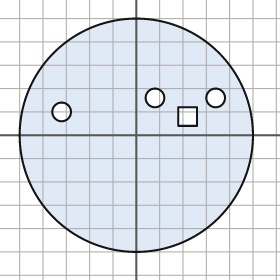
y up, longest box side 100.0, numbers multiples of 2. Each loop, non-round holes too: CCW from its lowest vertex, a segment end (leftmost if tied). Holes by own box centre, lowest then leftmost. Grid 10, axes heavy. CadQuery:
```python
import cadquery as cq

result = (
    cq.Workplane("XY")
    .moveTo(0.0, 0.0)
    .circle(50.0)
    .moveTo(18.0, 4.0)
    .lineTo(26.0, 4.0)
    .lineTo(26.0, 12.0)
    .lineTo(18.0, 12.0)
    .close()
    .moveTo(-32.0, 10.0)
    .circle(4.0)
    .moveTo(8.0, 16.0)
    .circle(4.0)
    .moveTo(34.0, 16.0)
    .circle(4.0)
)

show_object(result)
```